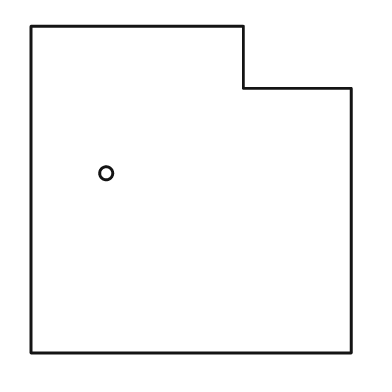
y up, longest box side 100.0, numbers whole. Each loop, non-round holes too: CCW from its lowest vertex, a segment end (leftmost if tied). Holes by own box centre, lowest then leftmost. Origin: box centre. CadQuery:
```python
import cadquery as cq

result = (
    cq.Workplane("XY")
    .moveTo(-49.0, -50.0)
    .lineTo(49.0, -50.0)
    .lineTo(49.0, 31.0)
    .lineTo(16.0, 31.0)
    .lineTo(16.0, 50.0)
    .lineTo(-49.0, 50.0)
    .close()
    .moveTo(-26.0, 5.0)
    .circle(2.0)
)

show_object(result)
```